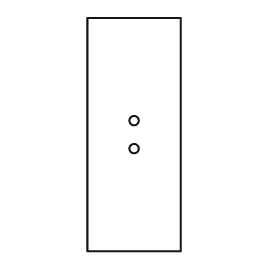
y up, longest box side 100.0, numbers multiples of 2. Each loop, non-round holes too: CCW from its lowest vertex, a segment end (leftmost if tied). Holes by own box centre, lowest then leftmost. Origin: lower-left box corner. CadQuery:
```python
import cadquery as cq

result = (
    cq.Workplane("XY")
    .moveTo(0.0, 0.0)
    .lineTo(40.0, 0.0)
    .lineTo(40.0, 100.0)
    .lineTo(0.0, 100.0)
    .close()
    .moveTo(20.0, 44.0)
    .circle(2.0)
    .moveTo(20.0, 56.0)
    .circle(2.0)
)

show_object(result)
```